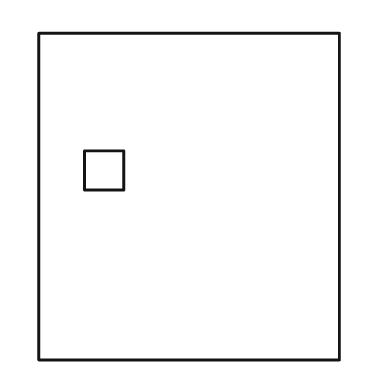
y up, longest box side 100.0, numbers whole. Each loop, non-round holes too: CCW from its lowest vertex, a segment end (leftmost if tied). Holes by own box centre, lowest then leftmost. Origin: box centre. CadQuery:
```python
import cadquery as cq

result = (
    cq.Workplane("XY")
    .moveTo(-46.0, -50.0)
    .lineTo(46.0, -50.0)
    .lineTo(46.0, 50.0)
    .lineTo(-46.0, 50.0)
    .close()
    .moveTo(-32.0, 2.0)
    .lineTo(-20.0, 2.0)
    .lineTo(-20.0, 14.0)
    .lineTo(-32.0, 14.0)
    .close()
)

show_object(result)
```